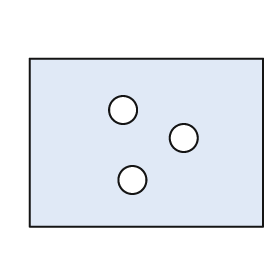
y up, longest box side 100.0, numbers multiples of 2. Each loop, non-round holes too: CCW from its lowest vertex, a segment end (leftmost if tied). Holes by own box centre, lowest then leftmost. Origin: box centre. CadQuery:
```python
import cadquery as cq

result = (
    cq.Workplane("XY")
    .moveTo(-50.0, -36.0)
    .lineTo(50.0, -36.0)
    .lineTo(50.0, 36.0)
    .lineTo(-50.0, 36.0)
    .close()
    .moveTo(-6.0, -16.0)
    .circle(6.0)
    .moveTo(16.0, 2.0)
    .circle(6.0)
    .moveTo(-10.0, 14.0)
    .circle(6.0)
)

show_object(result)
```